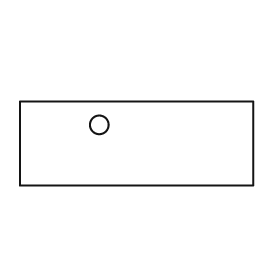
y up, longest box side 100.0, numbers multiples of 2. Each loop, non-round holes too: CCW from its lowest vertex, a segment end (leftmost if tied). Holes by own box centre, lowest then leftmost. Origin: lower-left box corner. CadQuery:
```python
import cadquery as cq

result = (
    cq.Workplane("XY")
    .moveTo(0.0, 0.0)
    .lineTo(100.0, 0.0)
    .lineTo(100.0, 36.0)
    .lineTo(0.0, 36.0)
    .close()
    .moveTo(34.0, 26.0)
    .circle(4.0)
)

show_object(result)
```